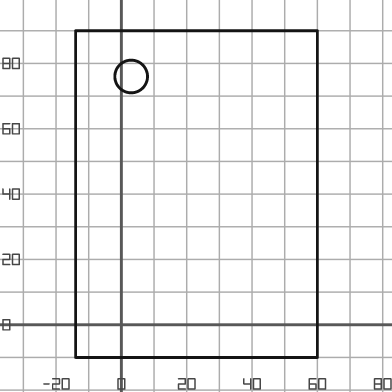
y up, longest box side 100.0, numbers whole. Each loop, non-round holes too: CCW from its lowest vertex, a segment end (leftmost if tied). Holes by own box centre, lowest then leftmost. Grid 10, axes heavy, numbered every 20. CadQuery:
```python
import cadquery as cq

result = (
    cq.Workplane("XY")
    .moveTo(-14.0, -10.0)
    .lineTo(60.0, -10.0)
    .lineTo(60.0, 90.0)
    .lineTo(-14.0, 90.0)
    .close()
    .moveTo(3.0, 76.0)
    .circle(5.0)
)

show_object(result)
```